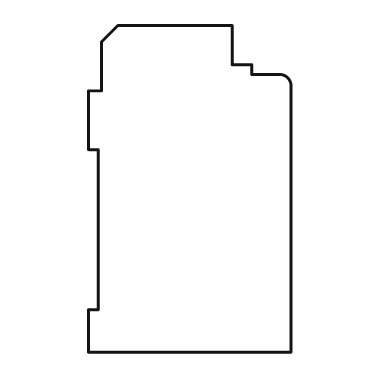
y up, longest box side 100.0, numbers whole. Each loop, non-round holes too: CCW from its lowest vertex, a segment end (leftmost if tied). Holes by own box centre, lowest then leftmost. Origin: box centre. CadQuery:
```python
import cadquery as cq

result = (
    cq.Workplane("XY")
    .moveTo(-31.0, -50.0)
    .lineTo(31.0, -50.0)
    .lineTo(31.0, 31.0)
    .threePointArc((30.0, 34.0), (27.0, 35.0))
    .lineTo(19.0, 35.0)
    .lineTo(19.0, 38.0)
    .lineTo(13.0, 38.0)
    .lineTo(13.0, 50.0)
    .lineTo(-22.0, 50.0)
    .lineTo(-27.0, 45.0)
    .lineTo(-27.0, 30.0)
    .lineTo(-31.0, 30.0)
    .lineTo(-31.0, 12.0)
    .lineTo(-28.0, 12.0)
    .lineTo(-28.0, -37.0)
    .lineTo(-31.0, -37.0)
    .close()
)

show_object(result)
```